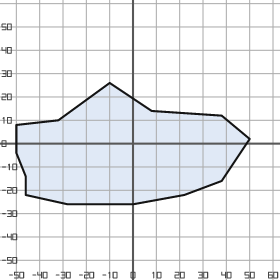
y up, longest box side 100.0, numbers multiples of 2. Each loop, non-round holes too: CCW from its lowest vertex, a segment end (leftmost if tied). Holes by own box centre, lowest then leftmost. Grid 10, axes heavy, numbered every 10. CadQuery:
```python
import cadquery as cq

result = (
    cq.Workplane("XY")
    .moveTo(-28.0, -26.0)
    .lineTo(0.0, -26.0)
    .lineTo(22.0, -22.0)
    .lineTo(38.0, -16.0)
    .lineTo(50.0, 2.0)
    .lineTo(38.0, 12.0)
    .lineTo(8.0, 14.0)
    .lineTo(-10.0, 26.0)
    .lineTo(-32.0, 10.0)
    .lineTo(-50.0, 8.0)
    .lineTo(-50.0, -4.0)
    .lineTo(-46.0, -14.0)
    .lineTo(-46.0, -22.0)
    .close()
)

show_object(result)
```